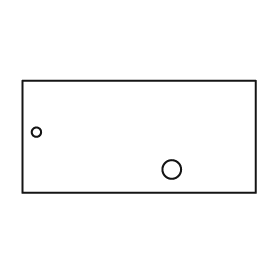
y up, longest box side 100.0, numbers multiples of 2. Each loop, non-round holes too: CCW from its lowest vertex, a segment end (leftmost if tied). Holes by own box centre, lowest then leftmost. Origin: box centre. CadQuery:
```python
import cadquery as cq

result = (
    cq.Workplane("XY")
    .moveTo(-50.0, -24.0)
    .lineTo(50.0, -24.0)
    .lineTo(50.0, 24.0)
    .lineTo(-50.0, 24.0)
    .close()
    .moveTo(14.0, -14.0)
    .circle(4.0)
    .moveTo(-44.0, 2.0)
    .circle(2.0)
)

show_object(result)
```